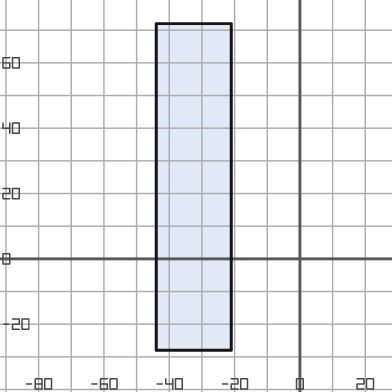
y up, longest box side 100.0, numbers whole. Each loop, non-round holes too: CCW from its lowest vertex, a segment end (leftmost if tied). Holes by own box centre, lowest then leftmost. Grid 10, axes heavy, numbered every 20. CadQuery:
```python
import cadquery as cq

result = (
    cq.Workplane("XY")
    .moveTo(-44.0, -28.0)
    .lineTo(-21.0, -28.0)
    .lineTo(-21.0, 72.0)
    .lineTo(-44.0, 72.0)
    .close()
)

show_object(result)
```